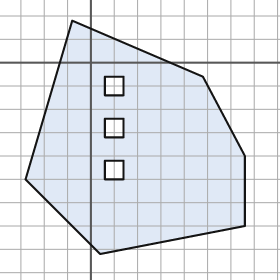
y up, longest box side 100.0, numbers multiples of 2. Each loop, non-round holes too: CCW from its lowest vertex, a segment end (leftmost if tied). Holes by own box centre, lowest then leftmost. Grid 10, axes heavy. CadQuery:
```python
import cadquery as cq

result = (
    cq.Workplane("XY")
    .moveTo(4.0, -82.0)
    .lineTo(66.0, -70.0)
    .lineTo(66.0, -40.0)
    .lineTo(48.0, -6.0)
    .lineTo(-8.0, 18.0)
    .lineTo(-28.0, -50.0)
    .close()
    .moveTo(6.0, -50.0)
    .lineTo(14.0, -50.0)
    .lineTo(14.0, -42.0)
    .lineTo(6.0, -42.0)
    .close()
    .moveTo(6.0, -32.0)
    .lineTo(14.0, -32.0)
    .lineTo(14.0, -24.0)
    .lineTo(6.0, -24.0)
    .close()
    .moveTo(6.0, -14.0)
    .lineTo(14.0, -14.0)
    .lineTo(14.0, -6.0)
    .lineTo(6.0, -6.0)
    .close()
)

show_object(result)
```